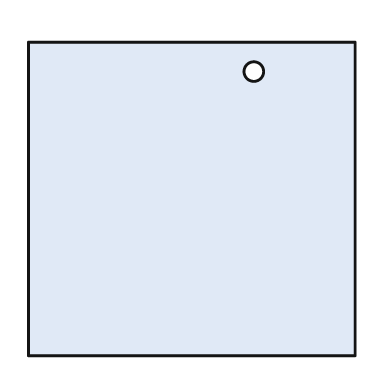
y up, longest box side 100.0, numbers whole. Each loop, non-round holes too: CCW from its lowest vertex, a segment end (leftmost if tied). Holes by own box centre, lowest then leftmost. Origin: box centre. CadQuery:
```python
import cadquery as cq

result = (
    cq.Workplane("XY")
    .moveTo(-50.0, -48.0)
    .lineTo(50.0, -48.0)
    .lineTo(50.0, 48.0)
    .lineTo(-50.0, 48.0)
    .close()
    .moveTo(19.0, 39.0)
    .circle(3.0)
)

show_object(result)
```